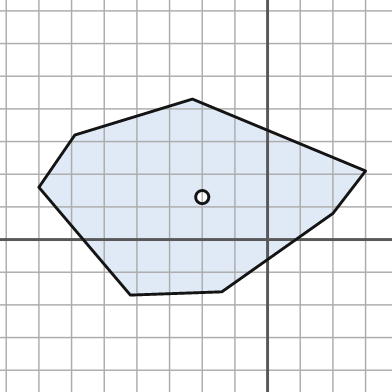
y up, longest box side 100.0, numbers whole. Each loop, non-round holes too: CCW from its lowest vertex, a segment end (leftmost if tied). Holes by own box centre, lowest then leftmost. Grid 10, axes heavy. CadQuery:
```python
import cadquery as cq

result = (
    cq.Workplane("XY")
    .moveTo(-42.0, -17.0)
    .lineTo(-14.0, -16.0)
    .lineTo(20.0, 8.0)
    .lineTo(30.0, 21.0)
    .lineTo(-23.0, 43.0)
    .lineTo(-59.0, 32.0)
    .lineTo(-70.0, 16.0)
    .close()
    .moveTo(-20.0, 13.0)
    .circle(2.0)
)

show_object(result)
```